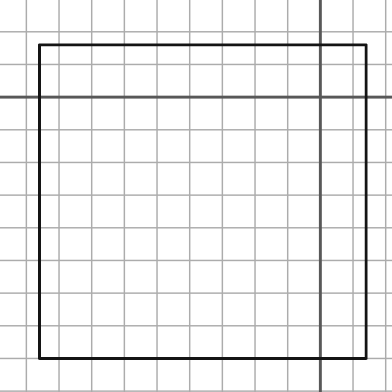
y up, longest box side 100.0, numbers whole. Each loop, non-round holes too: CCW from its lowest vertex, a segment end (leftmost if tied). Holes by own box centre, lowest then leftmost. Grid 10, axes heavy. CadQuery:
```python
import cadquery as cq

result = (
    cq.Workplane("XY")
    .moveTo(-86.0, -80.0)
    .lineTo(14.0, -80.0)
    .lineTo(14.0, 16.0)
    .lineTo(-86.0, 16.0)
    .close()
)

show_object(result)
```